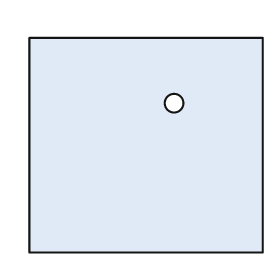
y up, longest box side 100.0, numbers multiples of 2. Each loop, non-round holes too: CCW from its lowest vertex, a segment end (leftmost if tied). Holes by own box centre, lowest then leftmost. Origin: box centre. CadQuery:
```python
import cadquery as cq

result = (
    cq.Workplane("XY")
    .moveTo(-50.0, -46.0)
    .lineTo(50.0, -46.0)
    .lineTo(50.0, 46.0)
    .lineTo(-50.0, 46.0)
    .close()
    .moveTo(12.0, 18.0)
    .circle(4.0)
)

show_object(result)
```